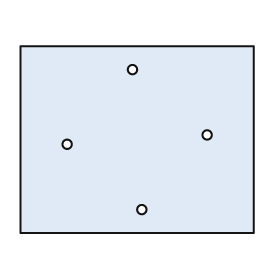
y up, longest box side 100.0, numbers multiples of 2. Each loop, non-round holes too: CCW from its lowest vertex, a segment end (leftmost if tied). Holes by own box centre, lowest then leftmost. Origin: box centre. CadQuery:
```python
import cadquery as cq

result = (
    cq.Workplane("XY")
    .moveTo(-50.0, -40.0)
    .lineTo(50.0, -40.0)
    .lineTo(50.0, 40.0)
    .lineTo(-50.0, 40.0)
    .close()
    .moveTo(2.0, -30.0)
    .circle(2.0)
    .moveTo(-30.0, -2.0)
    .circle(2.0)
    .moveTo(30.0, 2.0)
    .circle(2.0)
    .moveTo(-2.0, 30.0)
    .circle(2.0)
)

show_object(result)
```